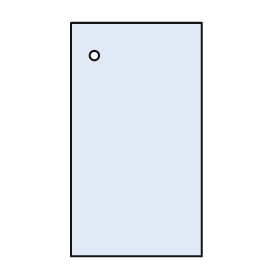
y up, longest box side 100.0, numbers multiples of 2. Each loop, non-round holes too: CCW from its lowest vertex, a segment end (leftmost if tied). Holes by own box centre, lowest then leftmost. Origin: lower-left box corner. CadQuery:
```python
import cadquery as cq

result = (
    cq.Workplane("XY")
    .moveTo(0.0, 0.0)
    .lineTo(56.0, 0.0)
    .lineTo(56.0, 100.0)
    .lineTo(0.0, 100.0)
    .close()
    .moveTo(10.0, 86.0)
    .circle(2.0)
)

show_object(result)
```